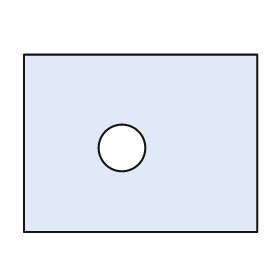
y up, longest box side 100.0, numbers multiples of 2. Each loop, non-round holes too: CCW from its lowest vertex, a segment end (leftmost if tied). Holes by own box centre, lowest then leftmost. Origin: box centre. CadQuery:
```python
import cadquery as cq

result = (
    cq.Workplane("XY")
    .moveTo(-50.0, -38.0)
    .lineTo(50.0, -38.0)
    .lineTo(50.0, 38.0)
    .lineTo(-50.0, 38.0)
    .close()
    .moveTo(-8.0, -2.0)
    .circle(10.0)
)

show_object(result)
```